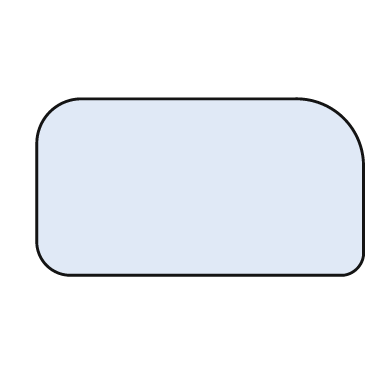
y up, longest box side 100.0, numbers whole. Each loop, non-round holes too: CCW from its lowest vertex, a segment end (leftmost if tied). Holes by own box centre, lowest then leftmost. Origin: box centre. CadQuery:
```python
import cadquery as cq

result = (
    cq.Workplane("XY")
    .moveTo(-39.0, -27.0)
    .lineTo(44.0, -27.0)
    .threePointArc((48.0, -25.0), (50.0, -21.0))
    .lineTo(50.0, 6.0)
    .threePointArc((44.0, 21.0), (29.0, 27.0))
    .lineTo(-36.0, 27.0)
    .threePointArc((-46.0, 23.0), (-50.0, 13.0))
    .lineTo(-50.0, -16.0)
    .threePointArc((-47.0, -24.0), (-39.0, -27.0))
    .close()
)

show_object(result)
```